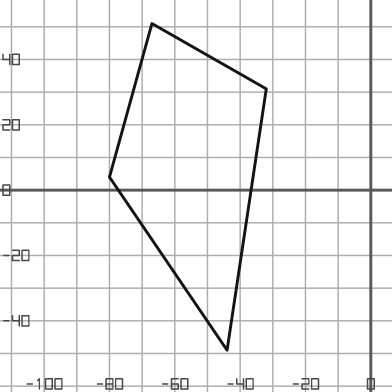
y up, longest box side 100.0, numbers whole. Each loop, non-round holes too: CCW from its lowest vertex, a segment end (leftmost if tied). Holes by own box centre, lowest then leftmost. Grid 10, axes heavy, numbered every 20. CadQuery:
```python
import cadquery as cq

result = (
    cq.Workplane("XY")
    .moveTo(-44.0, -49.0)
    .lineTo(-32.0, 31.0)
    .lineTo(-67.0, 51.0)
    .lineTo(-80.0, 4.0)
    .close()
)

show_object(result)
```